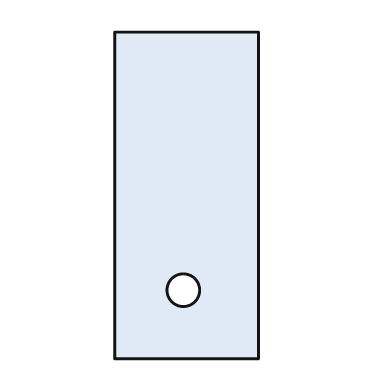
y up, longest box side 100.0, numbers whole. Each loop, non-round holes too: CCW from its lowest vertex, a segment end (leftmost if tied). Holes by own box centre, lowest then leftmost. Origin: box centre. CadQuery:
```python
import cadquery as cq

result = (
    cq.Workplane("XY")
    .moveTo(-22.0, -50.0)
    .lineTo(22.0, -50.0)
    .lineTo(22.0, 50.0)
    .lineTo(-22.0, 50.0)
    .close()
    .moveTo(-1.0, -29.0)
    .circle(5.0)
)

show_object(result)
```